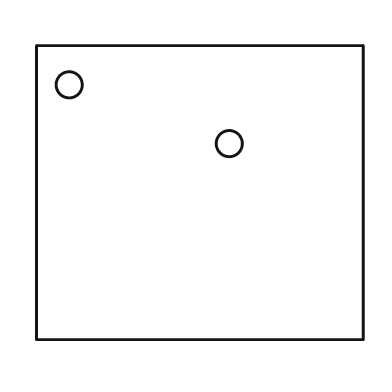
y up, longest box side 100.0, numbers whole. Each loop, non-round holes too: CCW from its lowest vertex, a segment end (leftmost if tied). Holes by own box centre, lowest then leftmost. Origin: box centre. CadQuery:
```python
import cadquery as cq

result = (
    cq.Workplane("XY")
    .moveTo(-50.0, -45.0)
    .lineTo(50.0, -45.0)
    .lineTo(50.0, 45.0)
    .lineTo(-50.0, 45.0)
    .close()
    .moveTo(9.0, 15.0)
    .circle(4.0)
    .moveTo(-40.0, 33.0)
    .circle(4.0)
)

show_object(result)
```